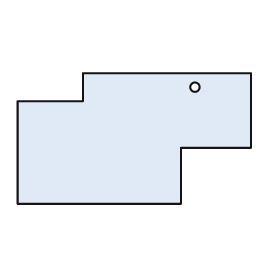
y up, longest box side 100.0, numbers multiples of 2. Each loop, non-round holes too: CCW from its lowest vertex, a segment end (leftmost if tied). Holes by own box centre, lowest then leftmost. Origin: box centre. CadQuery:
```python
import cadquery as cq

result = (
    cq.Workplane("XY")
    .moveTo(-50.0, -28.0)
    .lineTo(20.0, -28.0)
    .lineTo(20.0, -4.0)
    .lineTo(50.0, -4.0)
    .lineTo(50.0, 28.0)
    .lineTo(-22.0, 28.0)
    .lineTo(-22.0, 16.0)
    .lineTo(-50.0, 16.0)
    .close()
    .moveTo(26.0, 22.0)
    .circle(2.0)
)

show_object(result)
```